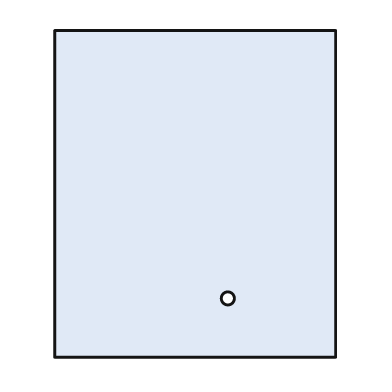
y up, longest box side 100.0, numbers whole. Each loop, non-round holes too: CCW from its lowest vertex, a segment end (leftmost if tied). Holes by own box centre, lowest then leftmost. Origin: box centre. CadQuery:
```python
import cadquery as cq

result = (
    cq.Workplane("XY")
    .moveTo(-43.0, -50.0)
    .lineTo(43.0, -50.0)
    .lineTo(43.0, 50.0)
    .lineTo(-43.0, 50.0)
    .close()
    .moveTo(10.0, -32.0)
    .circle(2.0)
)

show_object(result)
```